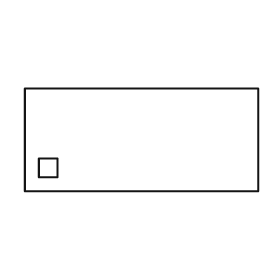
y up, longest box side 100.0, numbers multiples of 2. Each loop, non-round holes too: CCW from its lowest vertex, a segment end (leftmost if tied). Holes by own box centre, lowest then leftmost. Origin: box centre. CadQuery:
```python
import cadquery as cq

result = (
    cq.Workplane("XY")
    .moveTo(-50.0, -22.0)
    .lineTo(50.0, -22.0)
    .lineTo(50.0, 22.0)
    .lineTo(-50.0, 22.0)
    .close()
    .moveTo(-44.0, -16.0)
    .lineTo(-36.0, -16.0)
    .lineTo(-36.0, -8.0)
    .lineTo(-44.0, -8.0)
    .close()
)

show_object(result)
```